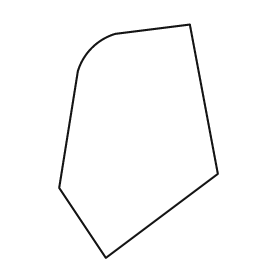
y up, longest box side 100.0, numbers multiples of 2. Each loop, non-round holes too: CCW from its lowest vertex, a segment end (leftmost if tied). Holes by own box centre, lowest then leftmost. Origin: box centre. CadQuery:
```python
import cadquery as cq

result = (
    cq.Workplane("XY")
    .moveTo(-14.0, -50.0)
    .lineTo(34.0, -14.0)
    .lineTo(22.0, 50.0)
    .lineTo(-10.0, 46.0)
    .threePointArc((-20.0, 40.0), (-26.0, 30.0))
    .lineTo(-34.0, -20.0)
    .close()
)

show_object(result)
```